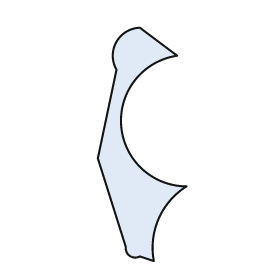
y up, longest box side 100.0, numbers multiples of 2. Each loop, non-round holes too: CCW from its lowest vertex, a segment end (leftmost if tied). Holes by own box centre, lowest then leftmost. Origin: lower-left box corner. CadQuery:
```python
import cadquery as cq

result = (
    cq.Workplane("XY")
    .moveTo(24.0, 0.0)
    .threePointArc((26.0, 18.0), (38.0, 32.0))
    .threePointArc((10.0, 58.0), (34.0, 88.0))
    .lineTo(18.0, 100.0)
    .threePointArc((8.0, 94.0), (8.0, 82.0))
    .lineTo(0.0, 44.0)
    .lineTo(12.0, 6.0)
    .threePointArc((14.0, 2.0), (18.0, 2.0))
    .close()
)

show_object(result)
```